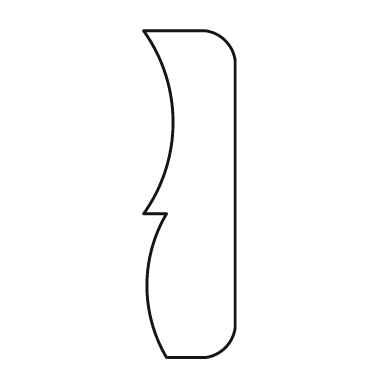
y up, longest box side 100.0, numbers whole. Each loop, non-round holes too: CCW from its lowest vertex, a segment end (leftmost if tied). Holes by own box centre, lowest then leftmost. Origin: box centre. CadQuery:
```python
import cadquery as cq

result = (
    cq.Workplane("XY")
    .moveTo(-7.0, -50.0)
    .lineTo(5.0, -50.0)
    .threePointArc((11.0, -47.0), (14.0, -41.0))
    .lineTo(14.0, 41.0)
    .threePointArc((11.0, 47.0), (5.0, 50.0))
    .lineTo(-14.0, 50.0)
    .threePointArc((-5.0, 22.0), (-14.0, -6.0))
    .lineTo(-7.0, -6.0)
    .threePointArc((-13.0, -28.0), (-7.0, -50.0))
    .close()
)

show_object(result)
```